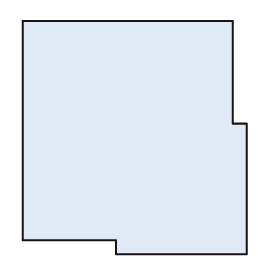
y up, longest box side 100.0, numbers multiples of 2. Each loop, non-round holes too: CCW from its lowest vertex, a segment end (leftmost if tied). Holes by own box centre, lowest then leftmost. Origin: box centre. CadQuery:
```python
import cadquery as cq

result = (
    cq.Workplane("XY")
    .moveTo(-8.0, -50.0)
    .lineTo(48.0, -50.0)
    .lineTo(48.0, 6.0)
    .lineTo(42.0, 6.0)
    .lineTo(42.0, 50.0)
    .lineTo(-48.0, 50.0)
    .lineTo(-48.0, -44.0)
    .lineTo(-8.0, -44.0)
    .close()
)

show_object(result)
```